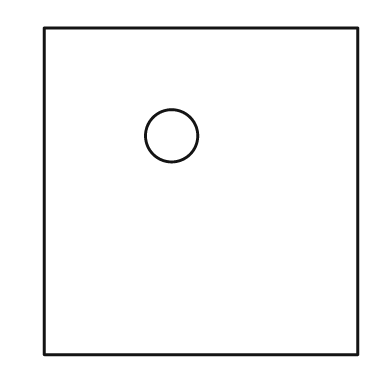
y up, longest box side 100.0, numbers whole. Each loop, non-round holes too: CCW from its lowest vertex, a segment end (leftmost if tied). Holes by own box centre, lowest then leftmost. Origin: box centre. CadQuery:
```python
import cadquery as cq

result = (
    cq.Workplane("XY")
    .moveTo(-48.0, -50.0)
    .lineTo(48.0, -50.0)
    .lineTo(48.0, 50.0)
    .lineTo(-48.0, 50.0)
    .close()
    .moveTo(-9.0, 17.0)
    .circle(8.0)
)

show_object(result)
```